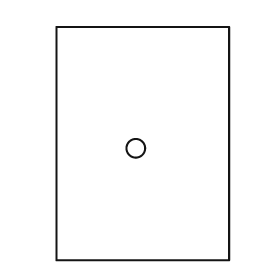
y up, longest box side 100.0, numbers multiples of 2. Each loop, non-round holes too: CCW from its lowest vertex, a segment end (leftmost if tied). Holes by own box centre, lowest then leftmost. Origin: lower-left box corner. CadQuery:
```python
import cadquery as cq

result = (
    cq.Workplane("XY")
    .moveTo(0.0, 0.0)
    .lineTo(74.0, 0.0)
    .lineTo(74.0, 100.0)
    .lineTo(0.0, 100.0)
    .close()
    .moveTo(34.0, 48.0)
    .circle(4.0)
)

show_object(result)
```